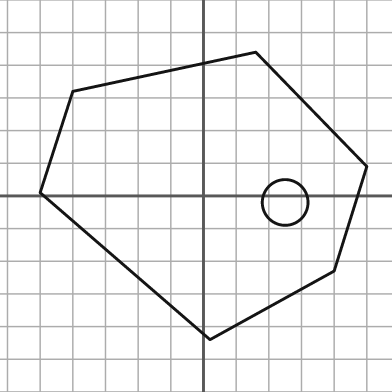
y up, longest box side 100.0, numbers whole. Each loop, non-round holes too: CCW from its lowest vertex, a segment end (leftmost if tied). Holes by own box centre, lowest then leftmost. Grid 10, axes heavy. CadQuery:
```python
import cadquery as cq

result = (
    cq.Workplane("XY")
    .moveTo(2.0, -44.0)
    .lineTo(40.0, -23.0)
    .lineTo(50.0, 9.0)
    .lineTo(16.0, 44.0)
    .lineTo(-40.0, 32.0)
    .lineTo(-50.0, 1.0)
    .close()
    .moveTo(25.0, -2.0)
    .circle(7.0)
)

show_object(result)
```